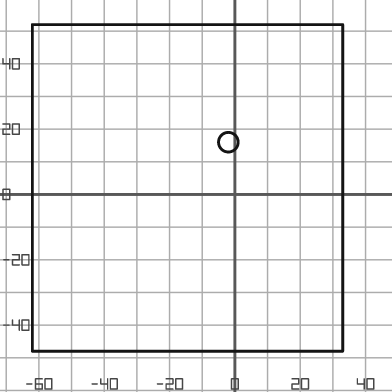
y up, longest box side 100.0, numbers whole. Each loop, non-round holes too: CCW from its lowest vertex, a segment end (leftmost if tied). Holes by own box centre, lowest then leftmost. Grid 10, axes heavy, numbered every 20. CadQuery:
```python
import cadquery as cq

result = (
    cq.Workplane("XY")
    .moveTo(-62.0, -48.0)
    .lineTo(33.0, -48.0)
    .lineTo(33.0, 52.0)
    .lineTo(-62.0, 52.0)
    .close()
    .moveTo(-2.0, 16.0)
    .circle(3.0)
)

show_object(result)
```